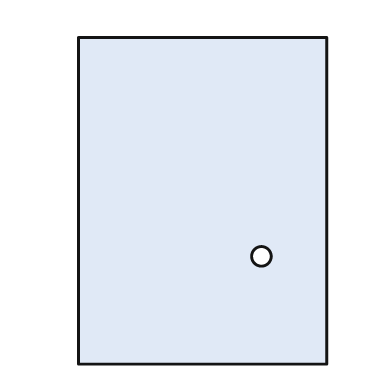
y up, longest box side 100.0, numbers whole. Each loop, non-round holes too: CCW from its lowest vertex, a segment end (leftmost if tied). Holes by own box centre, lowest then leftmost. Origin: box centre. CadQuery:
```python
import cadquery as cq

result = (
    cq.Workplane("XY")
    .moveTo(-38.0, -50.0)
    .lineTo(38.0, -50.0)
    .lineTo(38.0, 50.0)
    .lineTo(-38.0, 50.0)
    .close()
    .moveTo(18.0, -17.0)
    .circle(3.0)
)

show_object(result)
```